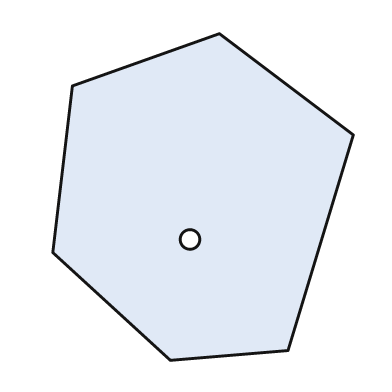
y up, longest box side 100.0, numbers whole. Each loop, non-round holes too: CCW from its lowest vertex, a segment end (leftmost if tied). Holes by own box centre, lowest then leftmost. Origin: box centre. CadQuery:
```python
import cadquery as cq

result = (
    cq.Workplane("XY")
    .moveTo(-10.0, -50.0)
    .lineTo(26.0, -47.0)
    .lineTo(46.0, 19.0)
    .lineTo(5.0, 50.0)
    .lineTo(-40.0, 34.0)
    .lineTo(-46.0, -17.0)
    .close()
    .moveTo(-4.0, -13.0)
    .circle(3.0)
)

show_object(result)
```